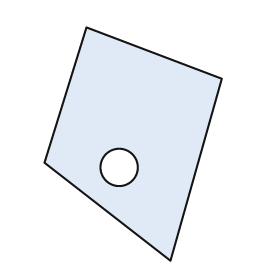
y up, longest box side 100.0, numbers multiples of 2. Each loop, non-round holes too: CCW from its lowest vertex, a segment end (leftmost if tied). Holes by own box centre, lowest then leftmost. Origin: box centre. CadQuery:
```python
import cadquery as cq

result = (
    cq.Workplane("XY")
    .moveTo(16.0, -50.0)
    .lineTo(38.0, 28.0)
    .lineTo(-20.0, 50.0)
    .lineTo(-38.0, -8.0)
    .close()
    .moveTo(-6.0, -10.0)
    .circle(8.0)
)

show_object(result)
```